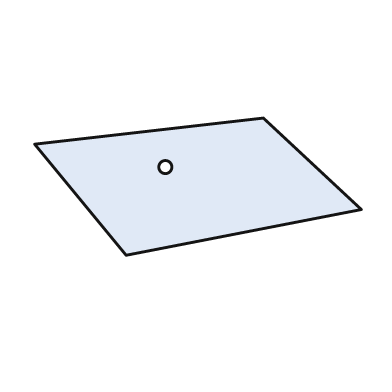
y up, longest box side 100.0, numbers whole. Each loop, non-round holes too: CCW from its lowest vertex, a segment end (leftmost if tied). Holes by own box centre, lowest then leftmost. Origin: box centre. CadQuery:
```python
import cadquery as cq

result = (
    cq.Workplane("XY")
    .moveTo(-22.0, -21.0)
    .lineTo(50.0, -7.0)
    .lineTo(20.0, 21.0)
    .lineTo(-50.0, 13.0)
    .close()
    .moveTo(-10.0, 6.0)
    .circle(2.0)
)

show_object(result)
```